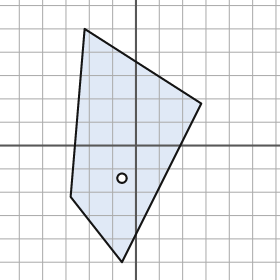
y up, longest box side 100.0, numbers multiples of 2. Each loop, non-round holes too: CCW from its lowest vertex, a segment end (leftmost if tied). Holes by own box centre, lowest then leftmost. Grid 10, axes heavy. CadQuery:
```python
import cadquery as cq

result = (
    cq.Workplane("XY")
    .moveTo(-6.0, -50.0)
    .lineTo(28.0, 18.0)
    .lineTo(-22.0, 50.0)
    .lineTo(-28.0, -22.0)
    .close()
    .moveTo(-6.0, -14.0)
    .circle(2.0)
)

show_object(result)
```